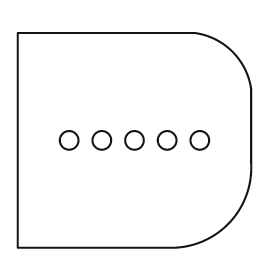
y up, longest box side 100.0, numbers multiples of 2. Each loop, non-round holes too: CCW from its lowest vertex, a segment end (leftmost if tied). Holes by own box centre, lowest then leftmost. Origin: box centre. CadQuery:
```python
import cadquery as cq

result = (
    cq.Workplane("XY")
    .moveTo(-50.0, -46.0)
    .lineTo(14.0, -46.0)
    .threePointArc((40.0, -36.0), (50.0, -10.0))
    .lineTo(50.0, 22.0)
    .threePointArc((42.0, 38.0), (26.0, 46.0))
    .lineTo(-50.0, 46.0)
    .close()
    .moveTo(-28.0, 0.0)
    .circle(4.0)
    .moveTo(-14.0, 0.0)
    .circle(4.0)
    .moveTo(0.0, 0.0)
    .circle(4.0)
    .moveTo(14.0, 0.0)
    .circle(4.0)
    .moveTo(28.0, 0.0)
    .circle(4.0)
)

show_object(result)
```